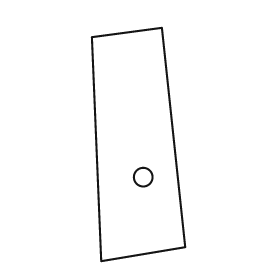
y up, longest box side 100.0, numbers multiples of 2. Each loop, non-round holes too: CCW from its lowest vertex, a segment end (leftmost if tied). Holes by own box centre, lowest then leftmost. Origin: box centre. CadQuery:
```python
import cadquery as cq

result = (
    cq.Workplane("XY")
    .moveTo(-16.0, -50.0)
    .lineTo(20.0, -44.0)
    .lineTo(10.0, 50.0)
    .lineTo(-20.0, 46.0)
    .close()
    .moveTo(2.0, -14.0)
    .circle(4.0)
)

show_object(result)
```